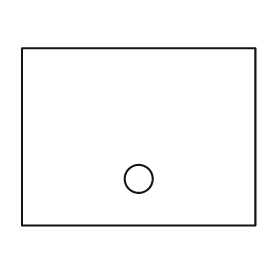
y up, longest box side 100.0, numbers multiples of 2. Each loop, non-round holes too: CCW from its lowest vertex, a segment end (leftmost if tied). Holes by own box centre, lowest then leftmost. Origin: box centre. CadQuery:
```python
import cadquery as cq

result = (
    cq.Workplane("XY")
    .moveTo(-50.0, -38.0)
    .lineTo(50.0, -38.0)
    .lineTo(50.0, 38.0)
    .lineTo(-50.0, 38.0)
    .close()
    .moveTo(0.0, -18.0)
    .circle(6.0)
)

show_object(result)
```